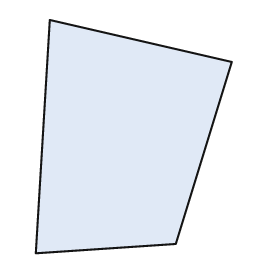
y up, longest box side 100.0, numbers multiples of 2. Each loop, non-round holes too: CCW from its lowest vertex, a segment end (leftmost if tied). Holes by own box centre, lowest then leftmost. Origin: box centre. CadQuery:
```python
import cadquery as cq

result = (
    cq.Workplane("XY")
    .moveTo(-42.0, -50.0)
    .lineTo(18.0, -46.0)
    .lineTo(42.0, 32.0)
    .lineTo(-36.0, 50.0)
    .close()
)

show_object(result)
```